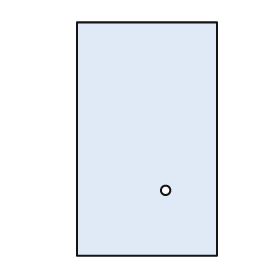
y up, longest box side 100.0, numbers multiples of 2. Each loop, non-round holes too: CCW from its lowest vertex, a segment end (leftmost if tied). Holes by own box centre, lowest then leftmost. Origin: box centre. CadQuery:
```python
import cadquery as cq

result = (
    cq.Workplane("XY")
    .moveTo(-30.0, -50.0)
    .lineTo(30.0, -50.0)
    .lineTo(30.0, 50.0)
    .lineTo(-30.0, 50.0)
    .close()
    .moveTo(8.0, -22.0)
    .circle(2.0)
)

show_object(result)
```